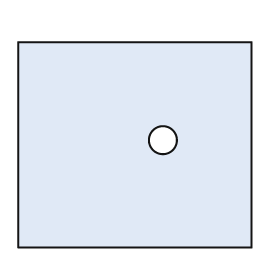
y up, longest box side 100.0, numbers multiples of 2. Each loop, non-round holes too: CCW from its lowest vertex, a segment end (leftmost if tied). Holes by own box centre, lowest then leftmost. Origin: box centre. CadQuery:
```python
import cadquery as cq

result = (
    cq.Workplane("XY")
    .moveTo(-50.0, -44.0)
    .lineTo(50.0, -44.0)
    .lineTo(50.0, 44.0)
    .lineTo(-50.0, 44.0)
    .close()
    .moveTo(12.0, 2.0)
    .circle(6.0)
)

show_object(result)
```